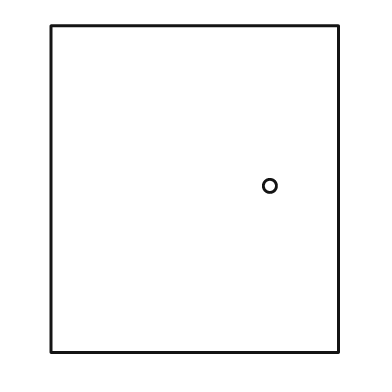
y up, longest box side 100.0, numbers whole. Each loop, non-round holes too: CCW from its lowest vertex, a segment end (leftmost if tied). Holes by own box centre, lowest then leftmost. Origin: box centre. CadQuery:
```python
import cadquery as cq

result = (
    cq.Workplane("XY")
    .moveTo(-44.0, -50.0)
    .lineTo(44.0, -50.0)
    .lineTo(44.0, 50.0)
    .lineTo(-44.0, 50.0)
    .close()
    .moveTo(23.0, 1.0)
    .circle(2.0)
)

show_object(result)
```